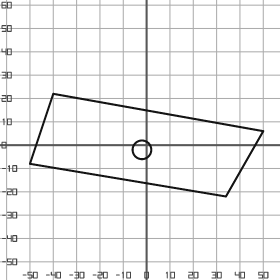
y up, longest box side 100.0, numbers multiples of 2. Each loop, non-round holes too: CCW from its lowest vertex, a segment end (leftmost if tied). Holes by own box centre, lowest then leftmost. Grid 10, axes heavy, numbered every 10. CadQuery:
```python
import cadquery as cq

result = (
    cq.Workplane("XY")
    .moveTo(34.0, -22.0)
    .lineTo(50.0, 6.0)
    .lineTo(-40.0, 22.0)
    .lineTo(-50.0, -8.0)
    .close()
    .moveTo(-2.0, -2.0)
    .circle(4.0)
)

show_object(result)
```